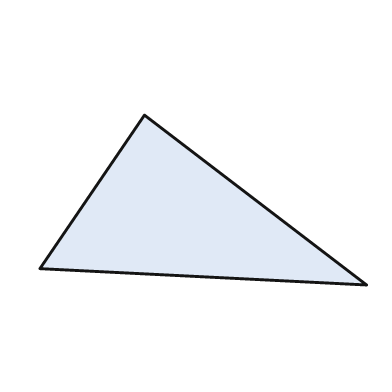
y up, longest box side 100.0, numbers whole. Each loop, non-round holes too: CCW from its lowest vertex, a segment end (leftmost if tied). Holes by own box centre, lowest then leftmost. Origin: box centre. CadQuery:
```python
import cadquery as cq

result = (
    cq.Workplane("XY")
    .moveTo(50.0, -26.0)
    .lineTo(-18.0, 26.0)
    .lineTo(-50.0, -21.0)
    .close()
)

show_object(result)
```